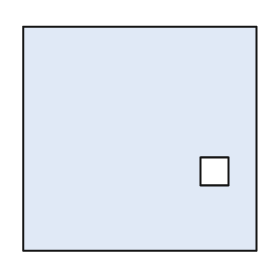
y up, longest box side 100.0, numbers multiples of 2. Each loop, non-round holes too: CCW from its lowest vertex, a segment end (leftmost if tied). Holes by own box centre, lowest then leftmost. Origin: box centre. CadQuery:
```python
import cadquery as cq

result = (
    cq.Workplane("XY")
    .moveTo(-50.0, -48.0)
    .lineTo(50.0, -48.0)
    .lineTo(50.0, 48.0)
    .lineTo(-50.0, 48.0)
    .close()
    .moveTo(26.0, -20.0)
    .lineTo(38.0, -20.0)
    .lineTo(38.0, -8.0)
    .lineTo(26.0, -8.0)
    .close()
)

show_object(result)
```